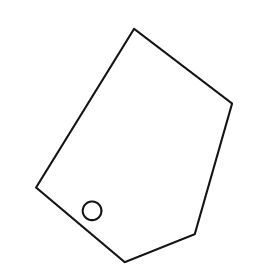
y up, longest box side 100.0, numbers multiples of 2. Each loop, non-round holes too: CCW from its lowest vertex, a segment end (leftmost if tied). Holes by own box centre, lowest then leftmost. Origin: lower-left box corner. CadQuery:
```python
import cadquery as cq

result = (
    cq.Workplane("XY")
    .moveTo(38.0, 0.0)
    .lineTo(68.0, 12.0)
    .lineTo(84.0, 68.0)
    .lineTo(42.0, 100.0)
    .lineTo(0.0, 32.0)
    .close()
    .moveTo(24.0, 22.0)
    .circle(4.0)
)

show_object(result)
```